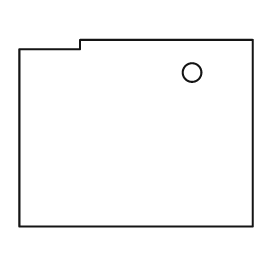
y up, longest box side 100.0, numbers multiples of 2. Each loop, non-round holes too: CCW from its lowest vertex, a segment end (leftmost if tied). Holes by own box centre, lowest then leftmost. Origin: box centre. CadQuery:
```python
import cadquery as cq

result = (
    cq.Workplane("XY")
    .moveTo(-50.0, -40.0)
    .lineTo(50.0, -40.0)
    .lineTo(50.0, 40.0)
    .lineTo(-24.0, 40.0)
    .lineTo(-24.0, 36.0)
    .lineTo(-50.0, 36.0)
    .close()
    .moveTo(24.0, 26.0)
    .circle(4.0)
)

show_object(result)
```